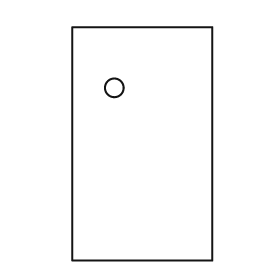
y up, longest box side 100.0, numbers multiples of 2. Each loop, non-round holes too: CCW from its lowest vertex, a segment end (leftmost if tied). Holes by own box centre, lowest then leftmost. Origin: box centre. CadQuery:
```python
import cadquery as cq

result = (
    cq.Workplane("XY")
    .moveTo(-30.0, -50.0)
    .lineTo(30.0, -50.0)
    .lineTo(30.0, 50.0)
    .lineTo(-30.0, 50.0)
    .close()
    .moveTo(-12.0, 24.0)
    .circle(4.0)
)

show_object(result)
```